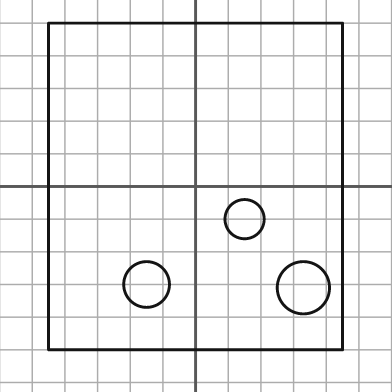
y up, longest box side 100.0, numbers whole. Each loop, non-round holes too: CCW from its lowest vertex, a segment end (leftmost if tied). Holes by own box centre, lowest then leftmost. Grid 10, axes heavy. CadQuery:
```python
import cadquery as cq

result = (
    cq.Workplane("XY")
    .moveTo(-45.0, -50.0)
    .lineTo(45.0, -50.0)
    .lineTo(45.0, 50.0)
    .lineTo(-45.0, 50.0)
    .close()
    .moveTo(33.0, -31.0)
    .circle(8.0)
    .moveTo(-15.0, -30.0)
    .circle(7.0)
    .moveTo(15.0, -10.0)
    .circle(6.0)
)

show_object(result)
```